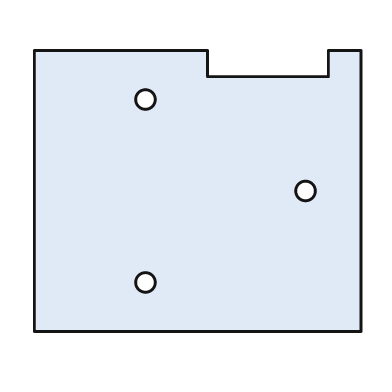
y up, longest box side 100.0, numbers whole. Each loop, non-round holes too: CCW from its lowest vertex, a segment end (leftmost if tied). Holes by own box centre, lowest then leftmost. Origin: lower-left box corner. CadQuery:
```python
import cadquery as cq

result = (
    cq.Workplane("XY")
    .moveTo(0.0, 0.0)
    .lineTo(100.0, 0.0)
    .lineTo(100.0, 86.0)
    .lineTo(90.0, 86.0)
    .lineTo(90.0, 78.0)
    .lineTo(53.0, 78.0)
    .lineTo(53.0, 86.0)
    .lineTo(0.0, 86.0)
    .close()
    .moveTo(34.0, 15.0)
    .circle(3.0)
    .moveTo(83.0, 43.0)
    .circle(3.0)
    .moveTo(34.0, 71.0)
    .circle(3.0)
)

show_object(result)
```